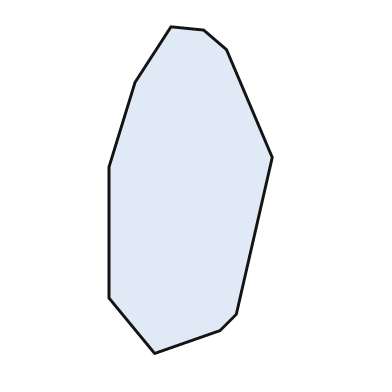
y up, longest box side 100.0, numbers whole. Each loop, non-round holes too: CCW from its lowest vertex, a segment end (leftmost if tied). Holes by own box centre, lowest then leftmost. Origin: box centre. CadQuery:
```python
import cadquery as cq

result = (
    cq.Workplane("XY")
    .moveTo(-11.0, -50.0)
    .lineTo(9.0, -43.0)
    .lineTo(14.0, -38.0)
    .lineTo(25.0, 10.0)
    .lineTo(11.0, 43.0)
    .lineTo(4.0, 49.0)
    .lineTo(-6.0, 50.0)
    .lineTo(-17.0, 33.0)
    .lineTo(-25.0, 7.0)
    .lineTo(-25.0, -33.0)
    .close()
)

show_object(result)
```